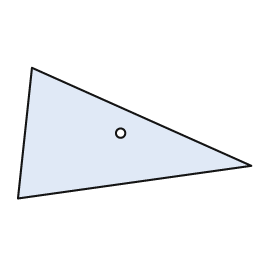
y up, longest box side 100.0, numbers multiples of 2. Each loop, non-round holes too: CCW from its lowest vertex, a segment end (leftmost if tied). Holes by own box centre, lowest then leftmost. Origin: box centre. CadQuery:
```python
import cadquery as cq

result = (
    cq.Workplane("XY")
    .moveTo(-50.0, -28.0)
    .lineTo(50.0, -14.0)
    .lineTo(-44.0, 28.0)
    .close()
    .moveTo(-6.0, 0.0)
    .circle(2.0)
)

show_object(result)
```